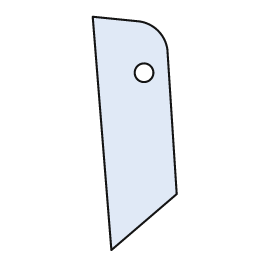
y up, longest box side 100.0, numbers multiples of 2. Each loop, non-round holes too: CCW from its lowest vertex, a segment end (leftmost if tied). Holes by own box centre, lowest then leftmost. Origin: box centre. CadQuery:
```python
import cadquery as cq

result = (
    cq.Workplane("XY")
    .moveTo(-10.0, -50.0)
    .lineTo(18.0, -26.0)
    .lineTo(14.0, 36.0)
    .threePointArc((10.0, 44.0), (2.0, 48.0))
    .lineTo(-18.0, 50.0)
    .close()
    .moveTo(4.0, 26.0)
    .circle(4.0)
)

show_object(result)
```